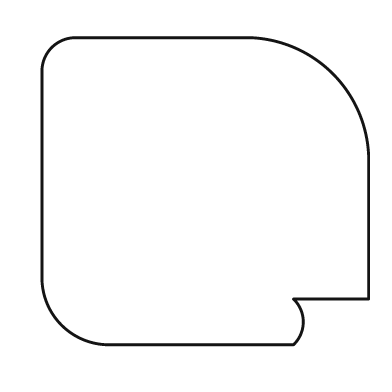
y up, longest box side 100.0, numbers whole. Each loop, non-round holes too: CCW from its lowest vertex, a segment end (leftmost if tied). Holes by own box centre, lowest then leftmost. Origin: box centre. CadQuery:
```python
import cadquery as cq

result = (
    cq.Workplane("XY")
    .moveTo(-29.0, -47.0)
    .lineTo(27.0, -47.0)
    .threePointArc((30.0, -40.0), (27.0, -33.0))
    .lineTo(50.0, -33.0)
    .lineTo(50.0, 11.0)
    .threePointArc((39.0, 36.0), (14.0, 47.0))
    .lineTo(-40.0, 47.0)
    .threePointArc((-47.0, 44.0), (-50.0, 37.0))
    .lineTo(-50.0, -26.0)
    .threePointArc((-44.0, -41.0), (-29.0, -47.0))
    .close()
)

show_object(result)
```